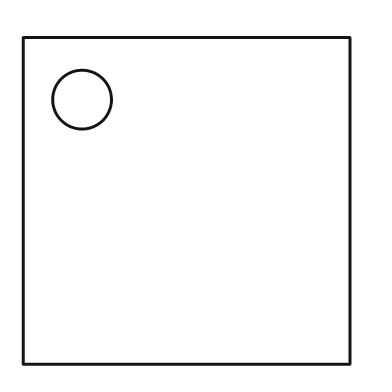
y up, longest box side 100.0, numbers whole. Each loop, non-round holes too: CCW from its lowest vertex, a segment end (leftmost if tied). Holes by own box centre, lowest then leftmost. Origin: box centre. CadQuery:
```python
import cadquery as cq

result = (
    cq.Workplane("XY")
    .moveTo(-50.0, -50.0)
    .lineTo(50.0, -50.0)
    .lineTo(50.0, 50.0)
    .lineTo(-50.0, 50.0)
    .close()
    .moveTo(-32.0, 31.0)
    .circle(9.0)
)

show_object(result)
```